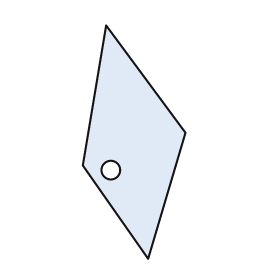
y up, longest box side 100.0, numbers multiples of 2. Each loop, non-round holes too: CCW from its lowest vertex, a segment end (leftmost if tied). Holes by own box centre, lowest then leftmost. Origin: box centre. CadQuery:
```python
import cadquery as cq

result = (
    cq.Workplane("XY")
    .moveTo(6.0, -50.0)
    .lineTo(22.0, 4.0)
    .lineTo(-12.0, 50.0)
    .lineTo(-22.0, -10.0)
    .close()
    .moveTo(-10.0, -12.0)
    .circle(4.0)
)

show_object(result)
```